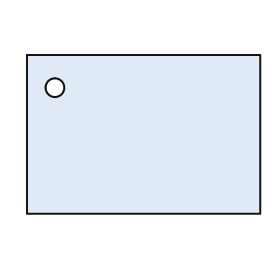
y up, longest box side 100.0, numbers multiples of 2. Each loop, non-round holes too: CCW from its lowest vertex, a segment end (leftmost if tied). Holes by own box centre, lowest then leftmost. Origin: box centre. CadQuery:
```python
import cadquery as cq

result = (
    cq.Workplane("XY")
    .moveTo(-50.0, -34.0)
    .lineTo(50.0, -34.0)
    .lineTo(50.0, 34.0)
    .lineTo(-50.0, 34.0)
    .close()
    .moveTo(-38.0, 20.0)
    .circle(4.0)
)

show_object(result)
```